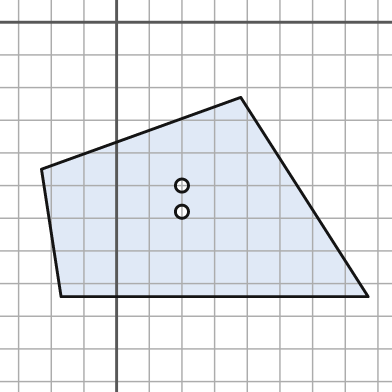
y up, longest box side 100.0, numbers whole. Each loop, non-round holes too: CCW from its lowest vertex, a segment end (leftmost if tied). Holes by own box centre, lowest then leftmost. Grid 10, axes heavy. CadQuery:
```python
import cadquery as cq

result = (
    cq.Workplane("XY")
    .moveTo(-17.0, -84.0)
    .lineTo(77.0, -84.0)
    .lineTo(38.0, -23.0)
    .lineTo(-23.0, -45.0)
    .close()
    .moveTo(20.0, -58.0)
    .circle(2.0)
    .moveTo(20.0, -50.0)
    .circle(2.0)
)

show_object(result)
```